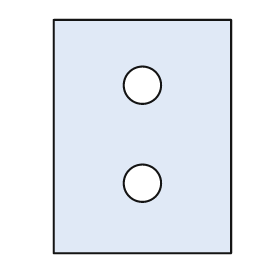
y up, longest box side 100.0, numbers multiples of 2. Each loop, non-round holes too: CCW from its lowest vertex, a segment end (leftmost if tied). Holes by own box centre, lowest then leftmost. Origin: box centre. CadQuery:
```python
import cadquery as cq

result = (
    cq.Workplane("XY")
    .moveTo(-38.0, -50.0)
    .lineTo(38.0, -50.0)
    .lineTo(38.0, 50.0)
    .lineTo(-38.0, 50.0)
    .close()
    .moveTo(0.0, -20.0)
    .circle(8.0)
    .moveTo(0.0, 22.0)
    .circle(8.0)
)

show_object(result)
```